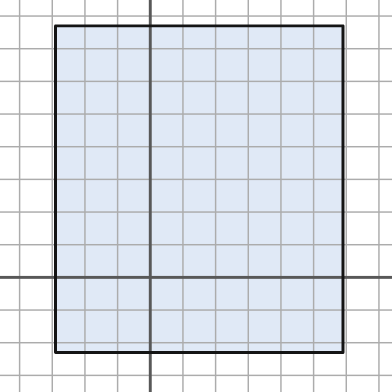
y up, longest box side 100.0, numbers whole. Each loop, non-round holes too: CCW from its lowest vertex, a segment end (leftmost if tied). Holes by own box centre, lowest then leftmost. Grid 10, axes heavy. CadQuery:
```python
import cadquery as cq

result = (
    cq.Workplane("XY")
    .moveTo(-29.0, -23.0)
    .lineTo(59.0, -23.0)
    .lineTo(59.0, 77.0)
    .lineTo(-29.0, 77.0)
    .close()
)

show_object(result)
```